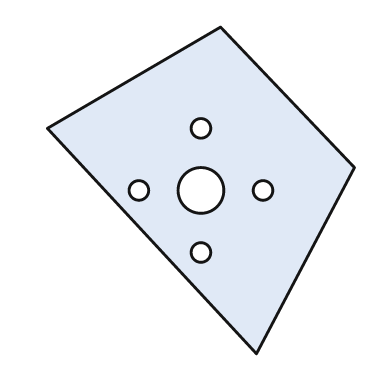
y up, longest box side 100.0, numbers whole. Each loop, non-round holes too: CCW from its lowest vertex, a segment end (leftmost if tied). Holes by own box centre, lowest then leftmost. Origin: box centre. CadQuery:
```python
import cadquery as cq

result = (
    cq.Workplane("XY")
    .moveTo(17.0, -50.0)
    .lineTo(47.0, 7.0)
    .lineTo(6.0, 50.0)
    .lineTo(-47.0, 19.0)
    .close()
    .moveTo(0.0, -19.0)
    .circle(3.0)
    .moveTo(-19.0, 0.0)
    .circle(3.0)
    .moveTo(0.0, 0.0)
    .circle(7.0)
    .moveTo(19.0, 0.0)
    .circle(3.0)
    .moveTo(0.0, 19.0)
    .circle(3.0)
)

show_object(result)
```